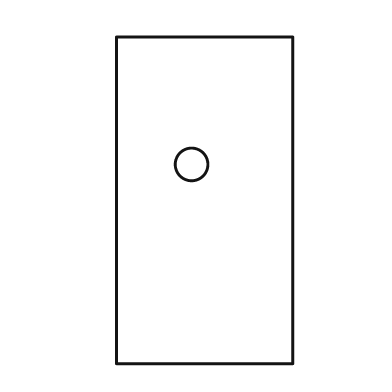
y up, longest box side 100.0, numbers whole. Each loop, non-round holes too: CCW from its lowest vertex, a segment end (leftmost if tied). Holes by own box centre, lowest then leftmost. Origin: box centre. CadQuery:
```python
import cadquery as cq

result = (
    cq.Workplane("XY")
    .moveTo(-27.0, -50.0)
    .lineTo(27.0, -50.0)
    .lineTo(27.0, 50.0)
    .lineTo(-27.0, 50.0)
    .close()
    .moveTo(-4.0, 11.0)
    .circle(5.0)
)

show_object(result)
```